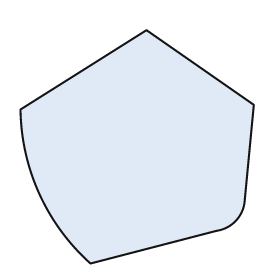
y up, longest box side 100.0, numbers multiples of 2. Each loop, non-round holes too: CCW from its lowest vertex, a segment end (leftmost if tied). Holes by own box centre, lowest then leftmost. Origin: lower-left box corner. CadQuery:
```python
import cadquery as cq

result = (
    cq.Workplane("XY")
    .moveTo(30.0, 0.0)
    .lineTo(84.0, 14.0)
    .threePointArc((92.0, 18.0), (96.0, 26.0))
    .lineTo(100.0, 68.0)
    .lineTo(54.0, 100.0)
    .lineTo(0.0, 66.0)
    .threePointArc((8.0, 30.0), (30.0, 0.0))
    .close()
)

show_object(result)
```